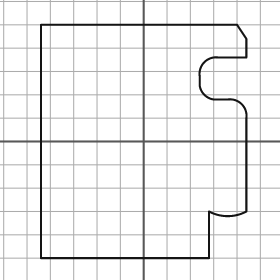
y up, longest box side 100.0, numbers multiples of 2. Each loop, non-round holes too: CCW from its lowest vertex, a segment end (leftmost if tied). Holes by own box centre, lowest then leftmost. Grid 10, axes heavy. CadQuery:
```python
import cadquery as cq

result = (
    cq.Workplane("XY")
    .moveTo(-44.0, -50.0)
    .lineTo(28.0, -50.0)
    .lineTo(28.0, -30.0)
    .threePointArc((36.0, -32.0), (44.0, -30.0))
    .lineTo(44.0, 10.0)
    .threePointArc((42.0, 16.0), (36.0, 18.0))
    .lineTo(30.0, 18.0)
    .threePointArc((26.0, 20.0), (24.0, 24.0))
    .lineTo(24.0, 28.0)
    .threePointArc((26.0, 34.0), (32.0, 36.0))
    .lineTo(44.0, 36.0)
    .lineTo(44.0, 44.0)
    .lineTo(40.0, 50.0)
    .lineTo(-44.0, 50.0)
    .close()
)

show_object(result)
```